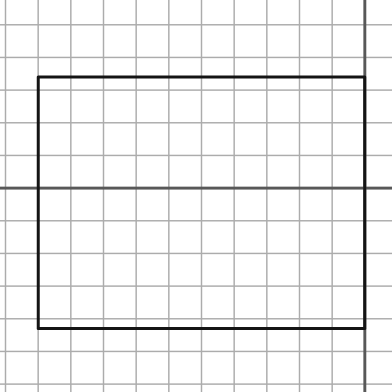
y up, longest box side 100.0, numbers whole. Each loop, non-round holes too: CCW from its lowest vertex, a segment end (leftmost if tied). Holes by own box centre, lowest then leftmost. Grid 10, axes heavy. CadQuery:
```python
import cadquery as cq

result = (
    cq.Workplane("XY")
    .moveTo(-100.0, -43.0)
    .lineTo(0.0, -43.0)
    .lineTo(0.0, 34.0)
    .lineTo(-100.0, 34.0)
    .close()
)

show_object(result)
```